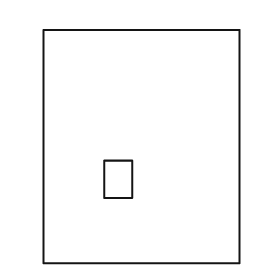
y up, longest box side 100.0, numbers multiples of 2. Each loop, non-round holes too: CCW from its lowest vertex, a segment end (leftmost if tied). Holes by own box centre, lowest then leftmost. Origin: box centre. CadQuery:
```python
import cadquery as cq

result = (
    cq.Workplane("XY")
    .moveTo(-42.0, -50.0)
    .lineTo(42.0, -50.0)
    .lineTo(42.0, 50.0)
    .lineTo(-42.0, 50.0)
    .close()
    .moveTo(-16.0, -22.0)
    .lineTo(-4.0, -22.0)
    .lineTo(-4.0, -6.0)
    .lineTo(-16.0, -6.0)
    .close()
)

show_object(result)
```